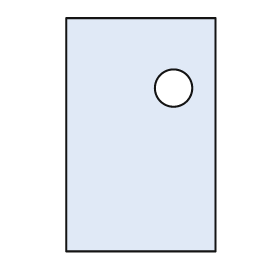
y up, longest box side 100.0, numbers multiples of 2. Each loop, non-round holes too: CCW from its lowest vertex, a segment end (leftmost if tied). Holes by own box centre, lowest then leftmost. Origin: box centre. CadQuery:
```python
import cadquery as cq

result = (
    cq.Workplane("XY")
    .moveTo(-32.0, -50.0)
    .lineTo(32.0, -50.0)
    .lineTo(32.0, 50.0)
    .lineTo(-32.0, 50.0)
    .close()
    .moveTo(14.0, 20.0)
    .circle(8.0)
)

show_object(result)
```